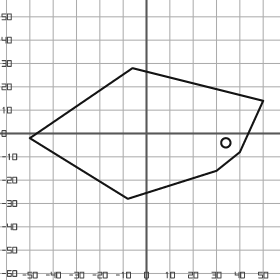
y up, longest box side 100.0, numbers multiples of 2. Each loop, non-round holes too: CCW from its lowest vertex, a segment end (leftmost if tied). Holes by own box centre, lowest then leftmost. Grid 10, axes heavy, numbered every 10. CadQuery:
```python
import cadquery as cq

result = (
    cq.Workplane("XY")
    .moveTo(-8.0, -28.0)
    .lineTo(30.0, -16.0)
    .lineTo(40.0, -8.0)
    .lineTo(50.0, 14.0)
    .lineTo(-6.0, 28.0)
    .lineTo(-50.0, -2.0)
    .close()
    .moveTo(34.0, -4.0)
    .circle(2.0)
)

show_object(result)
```